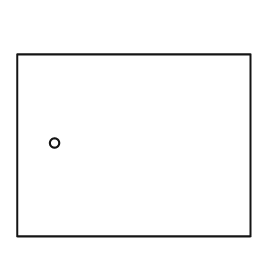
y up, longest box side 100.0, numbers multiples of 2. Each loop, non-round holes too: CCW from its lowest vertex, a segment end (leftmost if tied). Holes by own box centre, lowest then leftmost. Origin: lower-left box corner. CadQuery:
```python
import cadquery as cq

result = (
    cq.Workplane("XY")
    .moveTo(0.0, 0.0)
    .lineTo(100.0, 0.0)
    .lineTo(100.0, 78.0)
    .lineTo(0.0, 78.0)
    .close()
    .moveTo(16.0, 40.0)
    .circle(2.0)
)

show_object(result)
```